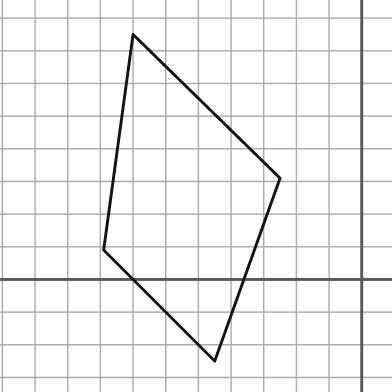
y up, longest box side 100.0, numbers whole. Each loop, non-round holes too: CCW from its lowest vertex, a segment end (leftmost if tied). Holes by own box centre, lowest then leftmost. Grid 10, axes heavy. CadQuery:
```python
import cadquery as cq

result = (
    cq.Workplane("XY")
    .moveTo(-45.0, -25.0)
    .lineTo(-25.0, 31.0)
    .lineTo(-70.0, 75.0)
    .lineTo(-79.0, 9.0)
    .close()
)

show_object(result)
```